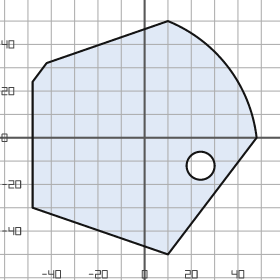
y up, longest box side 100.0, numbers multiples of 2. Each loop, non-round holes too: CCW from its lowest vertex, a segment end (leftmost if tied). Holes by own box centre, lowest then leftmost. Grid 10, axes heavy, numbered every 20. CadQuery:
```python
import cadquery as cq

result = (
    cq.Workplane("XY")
    .moveTo(10.0, -50.0)
    .lineTo(48.0, 0.0)
    .threePointArc((36.0, 30.0), (10.0, 50.0))
    .lineTo(-42.0, 32.0)
    .lineTo(-48.0, 24.0)
    .lineTo(-48.0, -30.0)
    .close()
    .moveTo(24.0, -12.0)
    .circle(6.0)
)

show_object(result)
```